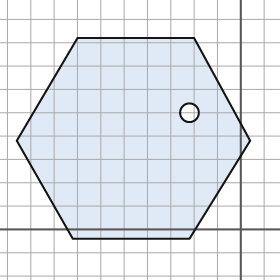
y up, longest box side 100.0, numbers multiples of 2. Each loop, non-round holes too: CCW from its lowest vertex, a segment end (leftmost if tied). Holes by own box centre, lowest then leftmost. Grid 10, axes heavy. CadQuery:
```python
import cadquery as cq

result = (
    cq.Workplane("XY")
    .moveTo(-72.0, -4.0)
    .lineTo(-22.0, -4.0)
    .lineTo(4.0, 38.0)
    .lineTo(-20.0, 82.0)
    .lineTo(-70.0, 82.0)
    .lineTo(-96.0, 38.0)
    .close()
    .moveTo(-22.0, 50.0)
    .circle(4.0)
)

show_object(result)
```